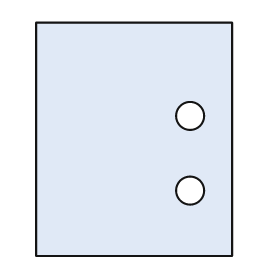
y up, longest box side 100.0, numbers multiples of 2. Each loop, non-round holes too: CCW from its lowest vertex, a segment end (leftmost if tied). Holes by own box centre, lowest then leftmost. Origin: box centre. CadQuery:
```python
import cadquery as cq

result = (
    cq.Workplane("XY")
    .moveTo(-42.0, -50.0)
    .lineTo(42.0, -50.0)
    .lineTo(42.0, 50.0)
    .lineTo(-42.0, 50.0)
    .close()
    .moveTo(24.0, -22.0)
    .circle(6.0)
    .moveTo(24.0, 10.0)
    .circle(6.0)
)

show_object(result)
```